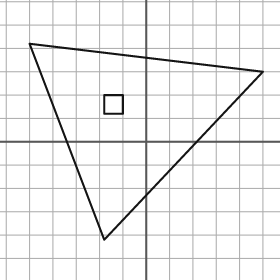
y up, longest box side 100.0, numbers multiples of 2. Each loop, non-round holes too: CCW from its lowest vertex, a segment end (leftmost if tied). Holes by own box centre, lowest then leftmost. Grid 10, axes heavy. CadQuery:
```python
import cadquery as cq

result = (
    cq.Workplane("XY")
    .moveTo(-18.0, -42.0)
    .lineTo(50.0, 30.0)
    .lineTo(-50.0, 42.0)
    .close()
    .moveTo(-18.0, 12.0)
    .lineTo(-10.0, 12.0)
    .lineTo(-10.0, 20.0)
    .lineTo(-18.0, 20.0)
    .close()
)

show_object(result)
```